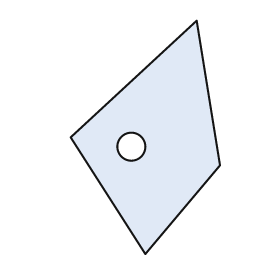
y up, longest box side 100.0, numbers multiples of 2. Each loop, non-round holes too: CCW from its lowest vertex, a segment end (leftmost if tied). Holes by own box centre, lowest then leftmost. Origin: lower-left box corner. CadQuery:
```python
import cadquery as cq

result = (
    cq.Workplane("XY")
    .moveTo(32.0, 0.0)
    .lineTo(64.0, 38.0)
    .lineTo(54.0, 100.0)
    .lineTo(0.0, 50.0)
    .close()
    .moveTo(26.0, 46.0)
    .circle(6.0)
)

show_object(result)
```